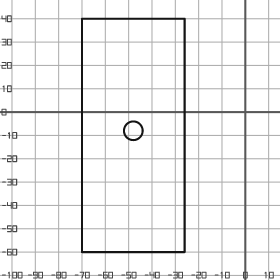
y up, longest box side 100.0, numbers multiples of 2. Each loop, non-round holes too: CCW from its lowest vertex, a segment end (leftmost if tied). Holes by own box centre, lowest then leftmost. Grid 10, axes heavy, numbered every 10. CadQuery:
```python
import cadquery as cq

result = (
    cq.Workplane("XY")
    .moveTo(-70.0, -60.0)
    .lineTo(-26.0, -60.0)
    .lineTo(-26.0, 40.0)
    .lineTo(-70.0, 40.0)
    .close()
    .moveTo(-48.0, -8.0)
    .circle(4.0)
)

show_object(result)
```